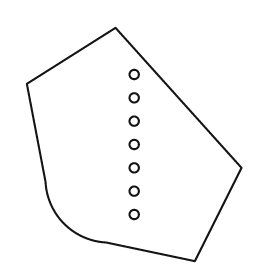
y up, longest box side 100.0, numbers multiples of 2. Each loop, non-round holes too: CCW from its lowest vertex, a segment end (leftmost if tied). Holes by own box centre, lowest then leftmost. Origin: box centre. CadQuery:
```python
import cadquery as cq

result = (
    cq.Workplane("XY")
    .moveTo(26.0, -50.0)
    .lineTo(46.0, -10.0)
    .lineTo(-8.0, 50.0)
    .lineTo(-46.0, 26.0)
    .lineTo(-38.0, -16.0)
    .threePointArc((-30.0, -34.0), (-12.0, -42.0))
    .close()
    .moveTo(0.0, -30.0)
    .circle(2.0)
    .moveTo(0.0, -20.0)
    .circle(2.0)
    .moveTo(0.0, -10.0)
    .circle(2.0)
    .moveTo(0.0, 0.0)
    .circle(2.0)
    .moveTo(0.0, 10.0)
    .circle(2.0)
    .moveTo(0.0, 20.0)
    .circle(2.0)
    .moveTo(0.0, 30.0)
    .circle(2.0)
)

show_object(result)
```